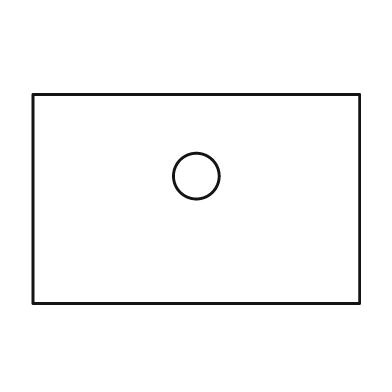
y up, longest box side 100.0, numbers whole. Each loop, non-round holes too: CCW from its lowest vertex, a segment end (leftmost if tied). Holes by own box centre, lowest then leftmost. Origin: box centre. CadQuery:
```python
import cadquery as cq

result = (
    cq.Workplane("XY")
    .moveTo(-50.0, -32.0)
    .lineTo(50.0, -32.0)
    .lineTo(50.0, 32.0)
    .lineTo(-50.0, 32.0)
    .close()
    .moveTo(0.0, 7.0)
    .circle(7.0)
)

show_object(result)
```